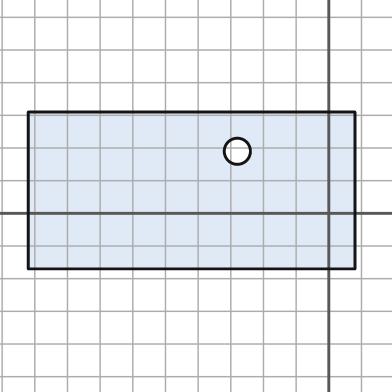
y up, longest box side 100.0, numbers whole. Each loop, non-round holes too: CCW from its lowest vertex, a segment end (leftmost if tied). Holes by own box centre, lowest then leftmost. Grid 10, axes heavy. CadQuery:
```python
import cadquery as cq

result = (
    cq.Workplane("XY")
    .moveTo(-92.0, -17.0)
    .lineTo(8.0, -17.0)
    .lineTo(8.0, 31.0)
    .lineTo(-92.0, 31.0)
    .close()
    .moveTo(-28.0, 19.0)
    .circle(4.0)
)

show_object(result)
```